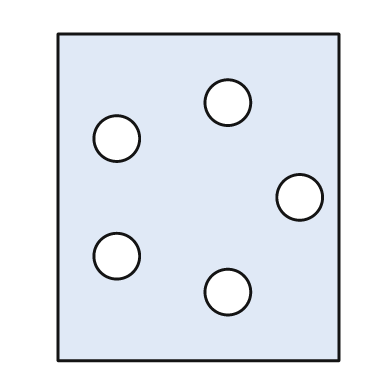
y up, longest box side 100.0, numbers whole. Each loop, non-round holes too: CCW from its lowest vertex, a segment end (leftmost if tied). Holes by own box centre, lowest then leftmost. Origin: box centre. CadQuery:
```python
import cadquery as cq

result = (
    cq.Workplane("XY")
    .moveTo(-43.0, -50.0)
    .lineTo(43.0, -50.0)
    .lineTo(43.0, 50.0)
    .lineTo(-43.0, 50.0)
    .close()
    .moveTo(9.0, -29.0)
    .circle(7.0)
    .moveTo(-25.0, -18.0)
    .circle(7.0)
    .moveTo(31.0, 0.0)
    .circle(7.0)
    .moveTo(-25.0, 18.0)
    .circle(7.0)
    .moveTo(9.0, 29.0)
    .circle(7.0)
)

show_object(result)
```